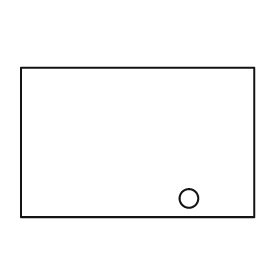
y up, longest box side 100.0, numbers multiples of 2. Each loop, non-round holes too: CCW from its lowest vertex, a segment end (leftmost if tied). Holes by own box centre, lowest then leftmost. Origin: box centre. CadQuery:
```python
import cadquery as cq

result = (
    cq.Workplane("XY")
    .moveTo(-50.0, -32.0)
    .lineTo(50.0, -32.0)
    .lineTo(50.0, 32.0)
    .lineTo(-50.0, 32.0)
    .close()
    .moveTo(22.0, -24.0)
    .circle(4.0)
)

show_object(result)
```